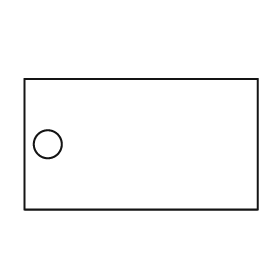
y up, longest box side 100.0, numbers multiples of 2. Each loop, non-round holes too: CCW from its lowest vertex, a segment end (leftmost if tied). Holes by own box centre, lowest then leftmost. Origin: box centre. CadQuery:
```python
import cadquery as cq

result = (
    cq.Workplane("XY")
    .moveTo(-50.0, -28.0)
    .lineTo(50.0, -28.0)
    .lineTo(50.0, 28.0)
    .lineTo(-50.0, 28.0)
    .close()
    .moveTo(-40.0, 0.0)
    .circle(6.0)
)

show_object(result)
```